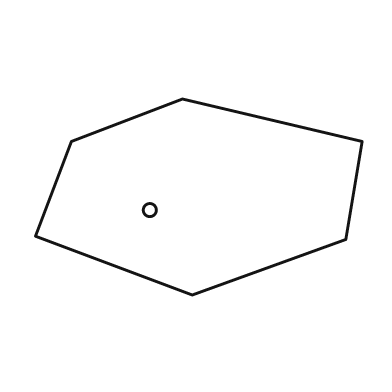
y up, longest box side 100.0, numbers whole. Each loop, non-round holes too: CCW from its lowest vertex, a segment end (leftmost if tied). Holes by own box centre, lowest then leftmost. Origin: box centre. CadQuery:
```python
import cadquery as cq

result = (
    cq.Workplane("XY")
    .moveTo(-2.0, -30.0)
    .lineTo(45.0, -13.0)
    .lineTo(50.0, 17.0)
    .lineTo(-5.0, 30.0)
    .lineTo(-39.0, 17.0)
    .lineTo(-50.0, -12.0)
    .close()
    .moveTo(-15.0, -4.0)
    .circle(2.0)
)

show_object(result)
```